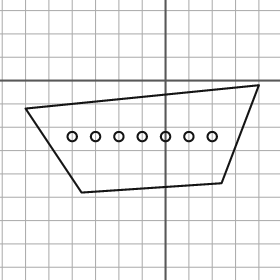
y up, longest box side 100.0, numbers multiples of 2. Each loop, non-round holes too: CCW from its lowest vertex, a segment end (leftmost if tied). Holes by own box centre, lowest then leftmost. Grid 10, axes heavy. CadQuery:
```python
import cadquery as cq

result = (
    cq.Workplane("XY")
    .moveTo(-36.0, -48.0)
    .lineTo(24.0, -44.0)
    .lineTo(40.0, -2.0)
    .lineTo(-60.0, -12.0)
    .close()
    .moveTo(-40.0, -24.0)
    .circle(2.0)
    .moveTo(-30.0, -24.0)
    .circle(2.0)
    .moveTo(-20.0, -24.0)
    .circle(2.0)
    .moveTo(-10.0, -24.0)
    .circle(2.0)
    .moveTo(0.0, -24.0)
    .circle(2.0)
    .moveTo(10.0, -24.0)
    .circle(2.0)
    .moveTo(20.0, -24.0)
    .circle(2.0)
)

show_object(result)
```